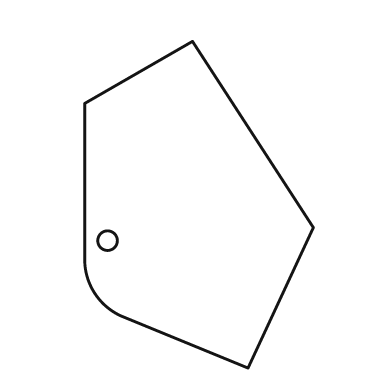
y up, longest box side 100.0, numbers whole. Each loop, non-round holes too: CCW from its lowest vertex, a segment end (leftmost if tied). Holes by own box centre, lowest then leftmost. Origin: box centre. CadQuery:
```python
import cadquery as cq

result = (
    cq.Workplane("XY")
    .moveTo(15.0, -50.0)
    .lineTo(35.0, -7.0)
    .lineTo(-2.0, 50.0)
    .lineTo(-35.0, 31.0)
    .lineTo(-35.0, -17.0)
    .threePointArc((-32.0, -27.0), (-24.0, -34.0))
    .close()
    .moveTo(-28.0, -11.0)
    .circle(3.0)
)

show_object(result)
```